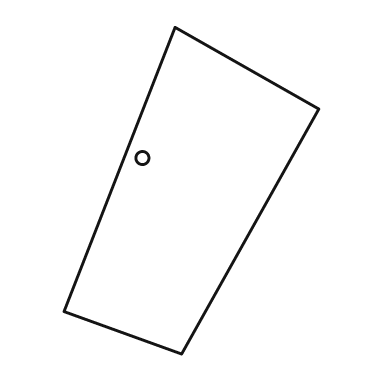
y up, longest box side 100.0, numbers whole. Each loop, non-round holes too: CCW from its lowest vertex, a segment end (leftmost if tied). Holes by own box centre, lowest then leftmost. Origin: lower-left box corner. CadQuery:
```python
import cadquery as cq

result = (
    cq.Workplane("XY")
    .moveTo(36.0, 0.0)
    .lineTo(78.0, 75.0)
    .lineTo(34.0, 100.0)
    .lineTo(0.0, 13.0)
    .close()
    .moveTo(24.0, 60.0)
    .circle(2.0)
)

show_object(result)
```